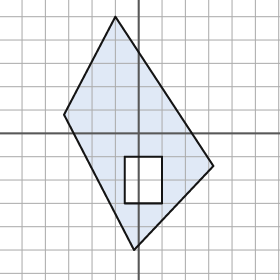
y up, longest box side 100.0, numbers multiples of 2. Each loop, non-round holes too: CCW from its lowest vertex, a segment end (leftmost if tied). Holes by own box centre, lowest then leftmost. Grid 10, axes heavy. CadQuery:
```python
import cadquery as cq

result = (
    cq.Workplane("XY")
    .moveTo(-2.0, -50.0)
    .lineTo(32.0, -14.0)
    .lineTo(-10.0, 50.0)
    .lineTo(-32.0, 8.0)
    .close()
    .moveTo(-6.0, -30.0)
    .lineTo(10.0, -30.0)
    .lineTo(10.0, -10.0)
    .lineTo(-6.0, -10.0)
    .close()
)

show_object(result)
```